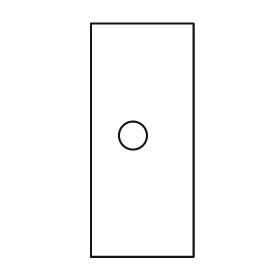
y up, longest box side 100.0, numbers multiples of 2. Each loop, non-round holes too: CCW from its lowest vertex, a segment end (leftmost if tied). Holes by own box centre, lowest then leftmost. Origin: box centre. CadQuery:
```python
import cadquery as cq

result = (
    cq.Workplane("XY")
    .moveTo(-22.0, -50.0)
    .lineTo(22.0, -50.0)
    .lineTo(22.0, 50.0)
    .lineTo(-22.0, 50.0)
    .close()
    .moveTo(-4.0, 2.0)
    .circle(6.0)
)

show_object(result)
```